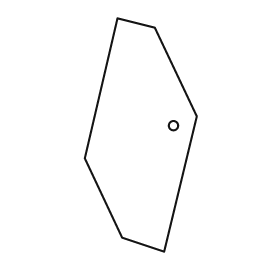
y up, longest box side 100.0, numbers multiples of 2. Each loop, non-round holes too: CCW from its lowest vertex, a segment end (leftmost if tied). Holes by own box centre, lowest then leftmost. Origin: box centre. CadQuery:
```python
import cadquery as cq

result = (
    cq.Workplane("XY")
    .moveTo(10.0, -50.0)
    .lineTo(24.0, 8.0)
    .lineTo(6.0, 46.0)
    .lineTo(-10.0, 50.0)
    .lineTo(-24.0, -10.0)
    .lineTo(-8.0, -44.0)
    .close()
    .moveTo(14.0, 4.0)
    .circle(2.0)
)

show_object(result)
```